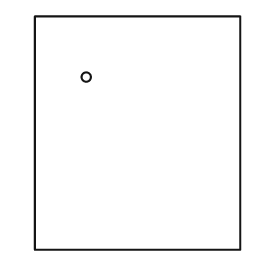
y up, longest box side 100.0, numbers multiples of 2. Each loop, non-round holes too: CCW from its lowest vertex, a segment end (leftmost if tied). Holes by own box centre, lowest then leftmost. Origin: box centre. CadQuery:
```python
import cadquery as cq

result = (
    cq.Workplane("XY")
    .moveTo(-44.0, -50.0)
    .lineTo(44.0, -50.0)
    .lineTo(44.0, 50.0)
    .lineTo(-44.0, 50.0)
    .close()
    .moveTo(-22.0, 24.0)
    .circle(2.0)
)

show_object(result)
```